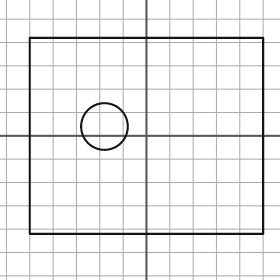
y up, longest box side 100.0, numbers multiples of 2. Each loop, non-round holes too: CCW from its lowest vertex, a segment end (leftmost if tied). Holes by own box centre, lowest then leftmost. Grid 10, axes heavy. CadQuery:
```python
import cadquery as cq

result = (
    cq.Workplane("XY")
    .moveTo(-50.0, -42.0)
    .lineTo(50.0, -42.0)
    .lineTo(50.0, 42.0)
    .lineTo(-50.0, 42.0)
    .close()
    .moveTo(-18.0, 4.0)
    .circle(10.0)
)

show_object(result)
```